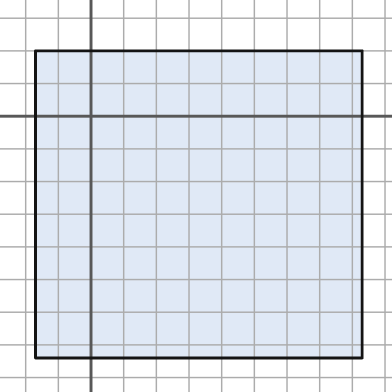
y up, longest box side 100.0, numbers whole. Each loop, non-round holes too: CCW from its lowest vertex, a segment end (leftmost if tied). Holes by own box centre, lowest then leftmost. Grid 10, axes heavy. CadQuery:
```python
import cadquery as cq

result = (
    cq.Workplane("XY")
    .moveTo(-17.0, -74.0)
    .lineTo(83.0, -74.0)
    .lineTo(83.0, 20.0)
    .lineTo(-17.0, 20.0)
    .close()
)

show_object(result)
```